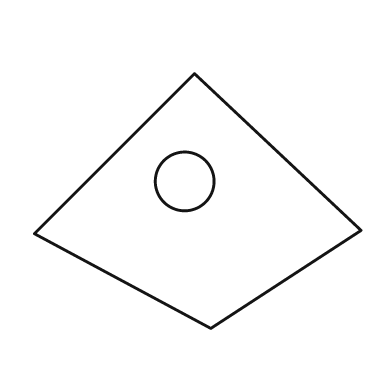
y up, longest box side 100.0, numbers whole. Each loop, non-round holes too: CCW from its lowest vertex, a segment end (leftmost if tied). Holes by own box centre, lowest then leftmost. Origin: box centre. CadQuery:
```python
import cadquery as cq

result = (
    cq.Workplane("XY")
    .moveTo(4.0, -39.0)
    .lineTo(50.0, -9.0)
    .lineTo(-1.0, 39.0)
    .lineTo(-50.0, -10.0)
    .close()
    .moveTo(-4.0, 6.0)
    .circle(9.0)
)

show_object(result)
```